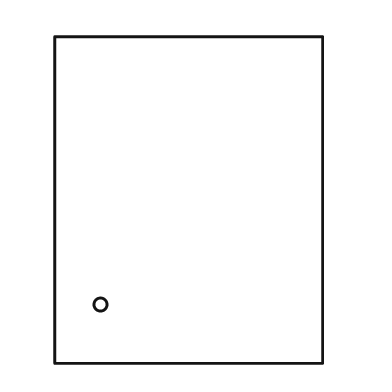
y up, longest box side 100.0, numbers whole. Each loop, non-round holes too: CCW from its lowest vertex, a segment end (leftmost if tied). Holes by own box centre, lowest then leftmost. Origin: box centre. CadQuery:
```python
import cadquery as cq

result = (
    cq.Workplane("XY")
    .moveTo(-41.0, -50.0)
    .lineTo(41.0, -50.0)
    .lineTo(41.0, 50.0)
    .lineTo(-41.0, 50.0)
    .close()
    .moveTo(-27.0, -32.0)
    .circle(2.0)
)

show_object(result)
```